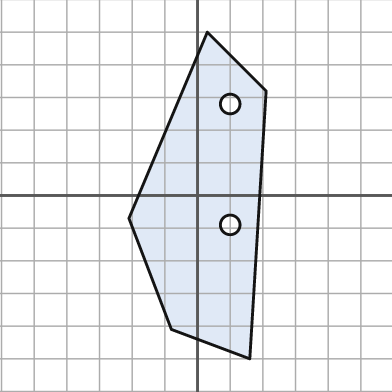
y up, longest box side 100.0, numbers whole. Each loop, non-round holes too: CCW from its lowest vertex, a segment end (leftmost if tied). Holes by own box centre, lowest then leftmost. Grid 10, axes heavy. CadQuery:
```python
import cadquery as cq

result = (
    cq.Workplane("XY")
    .moveTo(16.0, -50.0)
    .lineTo(21.0, 32.0)
    .lineTo(3.0, 50.0)
    .lineTo(-21.0, -7.0)
    .lineTo(-8.0, -41.0)
    .close()
    .moveTo(10.0, -9.0)
    .circle(3.0)
    .moveTo(10.0, 28.0)
    .circle(3.0)
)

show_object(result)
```